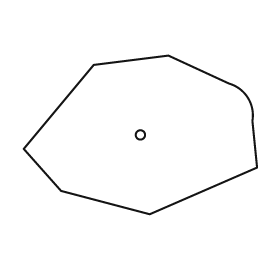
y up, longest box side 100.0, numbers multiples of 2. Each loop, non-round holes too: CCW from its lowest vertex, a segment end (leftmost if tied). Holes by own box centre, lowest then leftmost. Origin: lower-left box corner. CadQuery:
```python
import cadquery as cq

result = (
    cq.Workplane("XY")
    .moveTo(54.0, 0.0)
    .lineTo(100.0, 20.0)
    .lineTo(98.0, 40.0)
    .threePointArc((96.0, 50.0), (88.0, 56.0))
    .lineTo(62.0, 68.0)
    .lineTo(30.0, 64.0)
    .lineTo(0.0, 28.0)
    .lineTo(16.0, 10.0)
    .close()
    .moveTo(50.0, 34.0)
    .circle(2.0)
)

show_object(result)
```